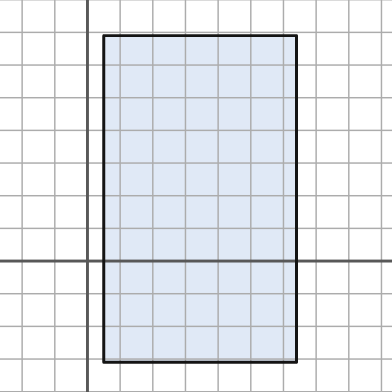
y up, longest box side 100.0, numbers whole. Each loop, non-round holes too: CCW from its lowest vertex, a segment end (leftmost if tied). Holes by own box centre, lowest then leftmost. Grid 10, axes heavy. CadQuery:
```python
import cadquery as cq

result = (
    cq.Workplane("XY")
    .moveTo(5.0, -31.0)
    .lineTo(64.0, -31.0)
    .lineTo(64.0, 69.0)
    .lineTo(5.0, 69.0)
    .close()
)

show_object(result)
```